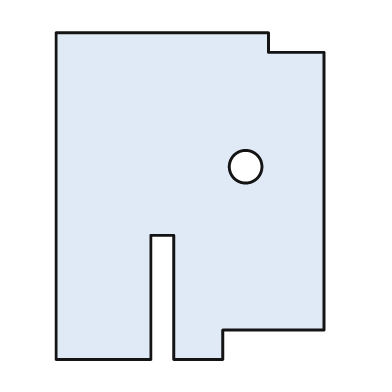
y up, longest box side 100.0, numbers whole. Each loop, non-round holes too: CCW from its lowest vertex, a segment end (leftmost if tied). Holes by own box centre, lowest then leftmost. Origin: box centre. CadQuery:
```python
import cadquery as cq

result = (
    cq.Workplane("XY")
    .moveTo(-41.0, -50.0)
    .lineTo(-12.0, -50.0)
    .lineTo(-12.0, -12.0)
    .lineTo(-5.0, -12.0)
    .lineTo(-5.0, -50.0)
    .lineTo(10.0, -50.0)
    .lineTo(10.0, -41.0)
    .lineTo(41.0, -41.0)
    .lineTo(41.0, 44.0)
    .lineTo(24.0, 44.0)
    .lineTo(24.0, 50.0)
    .lineTo(-41.0, 50.0)
    .close()
    .moveTo(17.0, 9.0)
    .circle(5.0)
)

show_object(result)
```